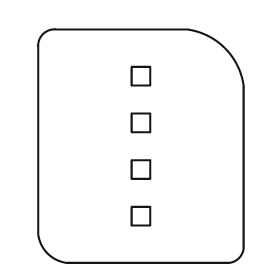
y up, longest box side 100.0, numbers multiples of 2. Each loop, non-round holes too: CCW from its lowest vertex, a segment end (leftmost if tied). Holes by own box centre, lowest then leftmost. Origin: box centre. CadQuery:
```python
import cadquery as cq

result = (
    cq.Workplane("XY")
    .moveTo(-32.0, -50.0)
    .lineTo(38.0, -50.0)
    .threePointArc((42.0, -48.0), (44.0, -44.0))
    .lineTo(44.0, 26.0)
    .threePointArc((36.0, 42.0), (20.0, 50.0))
    .lineTo(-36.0, 50.0)
    .threePointArc((-42.0, 48.0), (-44.0, 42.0))
    .lineTo(-44.0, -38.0)
    .threePointArc((-40.0, -46.0), (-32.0, -50.0))
    .close()
    .moveTo(-4.0, -34.0)
    .lineTo(4.0, -34.0)
    .lineTo(4.0, -26.0)
    .lineTo(-4.0, -26.0)
    .close()
    .moveTo(-4.0, -14.0)
    .lineTo(4.0, -14.0)
    .lineTo(4.0, -6.0)
    .lineTo(-4.0, -6.0)
    .close()
    .moveTo(-4.0, 6.0)
    .lineTo(4.0, 6.0)
    .lineTo(4.0, 14.0)
    .lineTo(-4.0, 14.0)
    .close()
    .moveTo(-4.0, 26.0)
    .lineTo(4.0, 26.0)
    .lineTo(4.0, 34.0)
    .lineTo(-4.0, 34.0)
    .close()
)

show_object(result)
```